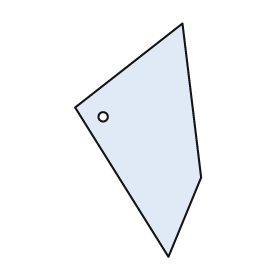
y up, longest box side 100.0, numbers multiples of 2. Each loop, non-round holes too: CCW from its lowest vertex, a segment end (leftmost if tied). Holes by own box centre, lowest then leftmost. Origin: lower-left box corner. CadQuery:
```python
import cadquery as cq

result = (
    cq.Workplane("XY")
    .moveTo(40.0, 0.0)
    .lineTo(54.0, 34.0)
    .lineTo(46.0, 100.0)
    .lineTo(0.0, 64.0)
    .close()
    .moveTo(12.0, 60.0)
    .circle(2.0)
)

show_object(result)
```